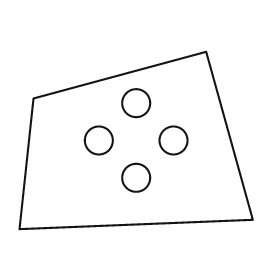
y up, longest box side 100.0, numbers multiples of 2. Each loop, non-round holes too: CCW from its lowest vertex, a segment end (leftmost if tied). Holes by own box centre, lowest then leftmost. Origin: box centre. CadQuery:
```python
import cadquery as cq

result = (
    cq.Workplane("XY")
    .moveTo(-50.0, -38.0)
    .lineTo(50.0, -34.0)
    .lineTo(30.0, 38.0)
    .lineTo(-44.0, 18.0)
    .close()
    .moveTo(0.0, -16.0)
    .circle(6.0)
    .moveTo(-16.0, 0.0)
    .circle(6.0)
    .moveTo(16.0, 0.0)
    .circle(6.0)
    .moveTo(0.0, 16.0)
    .circle(6.0)
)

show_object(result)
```